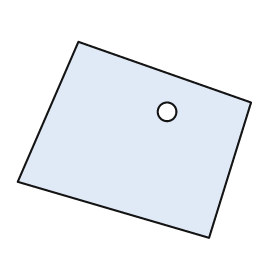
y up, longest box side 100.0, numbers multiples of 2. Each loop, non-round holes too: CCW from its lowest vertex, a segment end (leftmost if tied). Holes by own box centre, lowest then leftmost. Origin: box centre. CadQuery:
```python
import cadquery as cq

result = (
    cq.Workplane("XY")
    .moveTo(32.0, -42.0)
    .lineTo(50.0, 16.0)
    .lineTo(-24.0, 42.0)
    .lineTo(-50.0, -18.0)
    .close()
    .moveTo(14.0, 12.0)
    .circle(4.0)
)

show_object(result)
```